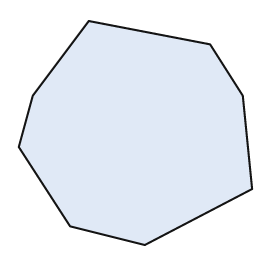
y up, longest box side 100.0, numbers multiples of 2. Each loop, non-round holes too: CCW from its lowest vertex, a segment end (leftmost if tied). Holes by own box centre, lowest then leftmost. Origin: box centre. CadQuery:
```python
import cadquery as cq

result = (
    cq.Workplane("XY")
    .moveTo(4.0, -48.0)
    .lineTo(50.0, -24.0)
    .lineTo(46.0, 16.0)
    .lineTo(32.0, 38.0)
    .lineTo(-20.0, 48.0)
    .lineTo(-44.0, 16.0)
    .lineTo(-50.0, -6.0)
    .lineTo(-28.0, -40.0)
    .close()
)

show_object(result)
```